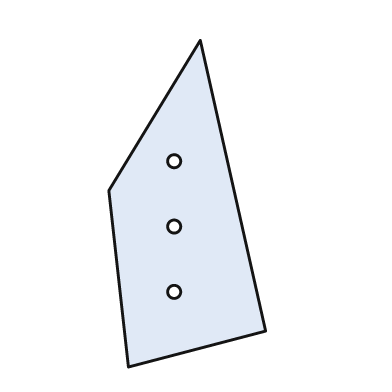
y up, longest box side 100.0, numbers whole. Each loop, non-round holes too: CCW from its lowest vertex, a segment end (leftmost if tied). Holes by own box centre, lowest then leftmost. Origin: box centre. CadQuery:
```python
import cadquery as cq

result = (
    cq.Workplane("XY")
    .moveTo(-18.0, -50.0)
    .lineTo(24.0, -39.0)
    .lineTo(4.0, 50.0)
    .lineTo(-24.0, 4.0)
    .close()
    .moveTo(-4.0, -27.0)
    .circle(2.0)
    .moveTo(-4.0, -7.0)
    .circle(2.0)
    .moveTo(-4.0, 13.0)
    .circle(2.0)
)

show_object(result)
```